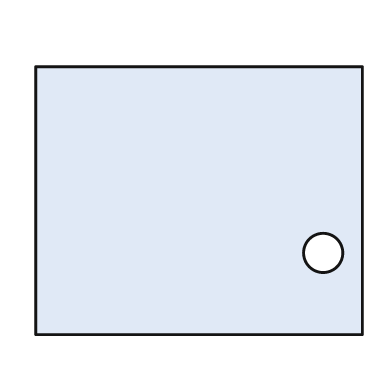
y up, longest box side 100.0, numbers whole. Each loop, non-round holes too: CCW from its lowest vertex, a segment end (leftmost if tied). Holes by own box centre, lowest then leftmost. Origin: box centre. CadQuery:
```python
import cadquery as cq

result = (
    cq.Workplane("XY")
    .moveTo(-50.0, -41.0)
    .lineTo(50.0, -41.0)
    .lineTo(50.0, 41.0)
    .lineTo(-50.0, 41.0)
    .close()
    .moveTo(38.0, -16.0)
    .circle(6.0)
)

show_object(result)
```